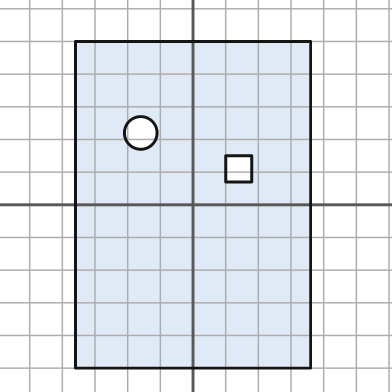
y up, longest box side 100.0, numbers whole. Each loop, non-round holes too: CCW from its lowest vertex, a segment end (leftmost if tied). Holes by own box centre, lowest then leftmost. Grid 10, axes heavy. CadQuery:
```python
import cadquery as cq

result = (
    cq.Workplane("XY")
    .moveTo(-36.0, -50.0)
    .lineTo(36.0, -50.0)
    .lineTo(36.0, 50.0)
    .lineTo(-36.0, 50.0)
    .close()
    .moveTo(10.0, 7.0)
    .lineTo(18.0, 7.0)
    .lineTo(18.0, 15.0)
    .lineTo(10.0, 15.0)
    .close()
    .moveTo(-16.0, 22.0)
    .circle(5.0)
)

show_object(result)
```